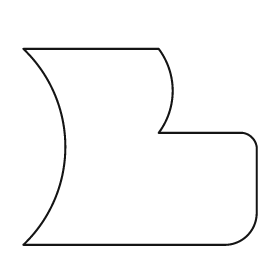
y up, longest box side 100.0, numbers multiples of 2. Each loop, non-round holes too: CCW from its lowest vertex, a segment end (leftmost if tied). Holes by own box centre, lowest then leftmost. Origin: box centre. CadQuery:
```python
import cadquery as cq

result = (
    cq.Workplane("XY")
    .moveTo(-50.0, -42.0)
    .lineTo(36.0, -42.0)
    .threePointArc((46.0, -38.0), (50.0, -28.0))
    .lineTo(50.0, 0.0)
    .threePointArc((48.0, 4.0), (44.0, 6.0))
    .lineTo(8.0, 6.0)
    .threePointArc((14.0, 24.0), (8.0, 42.0))
    .lineTo(-50.0, 42.0)
    .threePointArc((-32.0, 0.0), (-50.0, -42.0))
    .close()
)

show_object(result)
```